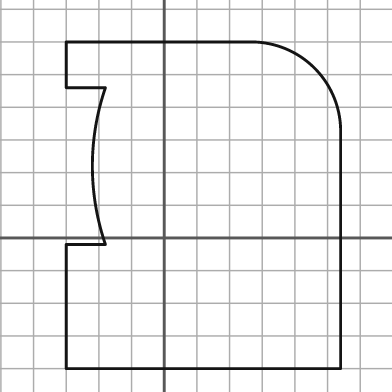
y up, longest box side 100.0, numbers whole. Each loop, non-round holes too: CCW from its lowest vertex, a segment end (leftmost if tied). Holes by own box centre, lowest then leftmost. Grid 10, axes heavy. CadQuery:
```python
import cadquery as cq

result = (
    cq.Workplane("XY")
    .moveTo(-30.0, -40.0)
    .lineTo(54.0, -40.0)
    .lineTo(54.0, 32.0)
    .threePointArc((46.0, 52.0), (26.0, 60.0))
    .lineTo(-30.0, 60.0)
    .lineTo(-30.0, 46.0)
    .lineTo(-18.0, 46.0)
    .threePointArc((-22.0, 22.0), (-18.0, -2.0))
    .lineTo(-30.0, -2.0)
    .close()
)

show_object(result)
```